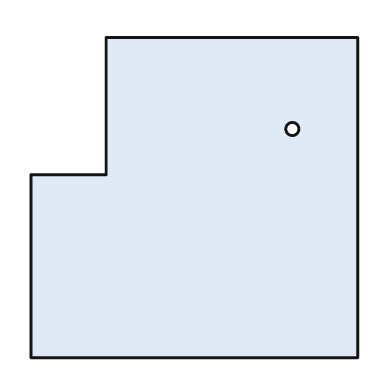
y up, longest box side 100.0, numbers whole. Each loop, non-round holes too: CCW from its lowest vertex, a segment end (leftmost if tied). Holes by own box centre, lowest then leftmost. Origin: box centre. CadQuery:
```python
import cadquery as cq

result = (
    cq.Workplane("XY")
    .moveTo(-50.0, -49.0)
    .lineTo(50.0, -49.0)
    .lineTo(50.0, 49.0)
    .lineTo(-27.0, 49.0)
    .lineTo(-27.0, 7.0)
    .lineTo(-50.0, 7.0)
    .close()
    .moveTo(30.0, 21.0)
    .circle(2.0)
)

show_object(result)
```